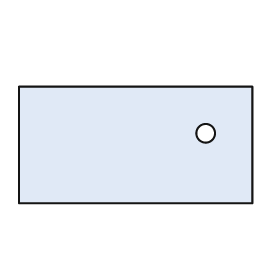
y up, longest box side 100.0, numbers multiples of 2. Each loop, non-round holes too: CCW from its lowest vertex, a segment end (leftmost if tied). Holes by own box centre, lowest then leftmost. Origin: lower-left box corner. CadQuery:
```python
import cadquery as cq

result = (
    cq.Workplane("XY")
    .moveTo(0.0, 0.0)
    .lineTo(100.0, 0.0)
    .lineTo(100.0, 50.0)
    .lineTo(0.0, 50.0)
    .close()
    .moveTo(80.0, 30.0)
    .circle(4.0)
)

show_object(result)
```